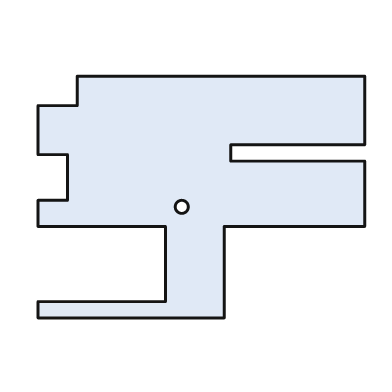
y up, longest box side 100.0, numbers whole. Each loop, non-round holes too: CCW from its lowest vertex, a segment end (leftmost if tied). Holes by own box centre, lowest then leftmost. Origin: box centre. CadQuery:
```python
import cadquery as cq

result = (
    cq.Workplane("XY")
    .moveTo(-50.0, -37.0)
    .lineTo(7.0, -37.0)
    .lineTo(7.0, -9.0)
    .lineTo(50.0, -9.0)
    .lineTo(50.0, 11.0)
    .lineTo(9.0, 11.0)
    .lineTo(9.0, 16.0)
    .lineTo(50.0, 16.0)
    .lineTo(50.0, 37.0)
    .lineTo(-38.0, 37.0)
    .lineTo(-38.0, 28.0)
    .lineTo(-50.0, 28.0)
    .lineTo(-50.0, 13.0)
    .lineTo(-41.0, 13.0)
    .lineTo(-41.0, -1.0)
    .lineTo(-50.0, -1.0)
    .lineTo(-50.0, -9.0)
    .lineTo(-11.0, -9.0)
    .lineTo(-11.0, -32.0)
    .lineTo(-50.0, -32.0)
    .close()
    .moveTo(-6.0, -3.0)
    .circle(2.0)
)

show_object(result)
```